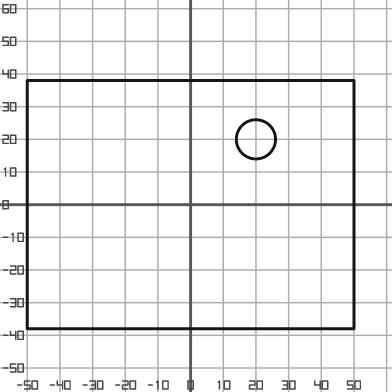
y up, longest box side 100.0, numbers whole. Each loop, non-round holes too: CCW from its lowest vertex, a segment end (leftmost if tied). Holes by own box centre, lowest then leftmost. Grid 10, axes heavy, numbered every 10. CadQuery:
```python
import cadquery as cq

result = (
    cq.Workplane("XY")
    .moveTo(-50.0, -38.0)
    .lineTo(50.0, -38.0)
    .lineTo(50.0, 38.0)
    .lineTo(-50.0, 38.0)
    .close()
    .moveTo(20.0, 20.0)
    .circle(6.0)
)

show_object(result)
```